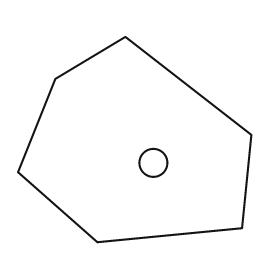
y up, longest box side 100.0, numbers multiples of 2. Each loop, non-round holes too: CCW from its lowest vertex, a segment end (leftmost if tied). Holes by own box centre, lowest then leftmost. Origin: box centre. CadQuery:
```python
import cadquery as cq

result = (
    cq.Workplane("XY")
    .moveTo(-16.0, -44.0)
    .lineTo(46.0, -38.0)
    .lineTo(50.0, 2.0)
    .lineTo(-4.0, 44.0)
    .lineTo(-34.0, 26.0)
    .lineTo(-50.0, -14.0)
    .close()
    .moveTo(8.0, -10.0)
    .circle(6.0)
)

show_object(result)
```